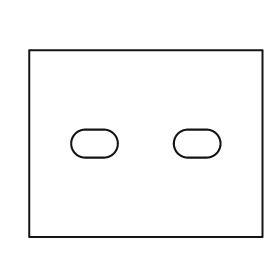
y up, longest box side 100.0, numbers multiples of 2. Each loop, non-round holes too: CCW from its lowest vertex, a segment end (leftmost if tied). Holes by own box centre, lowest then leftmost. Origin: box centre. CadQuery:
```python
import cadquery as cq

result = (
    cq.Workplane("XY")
    .moveTo(-50.0, -40.0)
    .lineTo(50.0, -40.0)
    .lineTo(50.0, 40.0)
    .lineTo(-50.0, 40.0)
    .close()
    .moveTo(-26.0, -6.0)
    .lineTo(-18.0, -6.0)
    .threePointArc((-12.0, 0.0), (-18.0, 6.0))
    .lineTo(-26.0, 6.0)
    .threePointArc((-32.0, 0.0), (-26.0, -6.0))
    .close()
    .moveTo(18.0, -6.0)
    .lineTo(26.0, -6.0)
    .threePointArc((32.0, 0.0), (26.0, 6.0))
    .lineTo(18.0, 6.0)
    .threePointArc((12.0, 0.0), (18.0, -6.0))
    .close()
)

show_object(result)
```